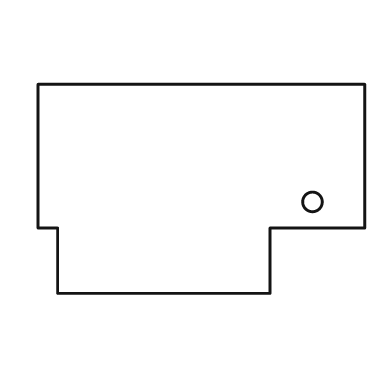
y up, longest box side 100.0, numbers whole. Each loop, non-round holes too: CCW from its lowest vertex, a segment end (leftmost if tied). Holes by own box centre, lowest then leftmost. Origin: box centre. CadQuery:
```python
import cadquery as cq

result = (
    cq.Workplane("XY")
    .moveTo(-44.0, -32.0)
    .lineTo(21.0, -32.0)
    .lineTo(21.0, -12.0)
    .lineTo(50.0, -12.0)
    .lineTo(50.0, 32.0)
    .lineTo(-50.0, 32.0)
    .lineTo(-50.0, -12.0)
    .lineTo(-44.0, -12.0)
    .close()
    .moveTo(34.0, -4.0)
    .circle(3.0)
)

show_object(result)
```